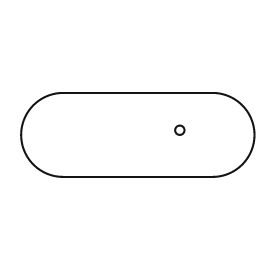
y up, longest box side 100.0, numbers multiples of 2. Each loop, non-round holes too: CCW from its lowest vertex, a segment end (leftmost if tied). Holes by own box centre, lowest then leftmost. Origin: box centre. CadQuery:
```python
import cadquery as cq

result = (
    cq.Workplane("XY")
    .moveTo(-32.0, -18.0)
    .lineTo(32.0, -18.0)
    .threePointArc((50.0, 0.0), (32.0, 18.0))
    .lineTo(-32.0, 18.0)
    .threePointArc((-50.0, 0.0), (-32.0, -18.0))
    .close()
    .moveTo(18.0, 2.0)
    .circle(2.0)
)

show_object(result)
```